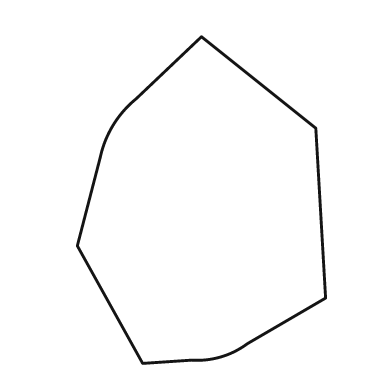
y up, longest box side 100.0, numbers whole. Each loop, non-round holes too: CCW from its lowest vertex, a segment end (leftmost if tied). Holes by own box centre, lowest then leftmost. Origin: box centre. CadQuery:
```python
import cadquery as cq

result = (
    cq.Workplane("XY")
    .moveTo(-18.0, -50.0)
    .lineTo(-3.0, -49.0)
    .threePointArc((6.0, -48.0), (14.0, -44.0))
    .lineTo(38.0, -30.0)
    .lineTo(35.0, 22.0)
    .lineTo(0.0, 50.0)
    .lineTo(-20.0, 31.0)
    .threePointArc((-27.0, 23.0), (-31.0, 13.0))
    .lineTo(-38.0, -14.0)
    .close()
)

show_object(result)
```